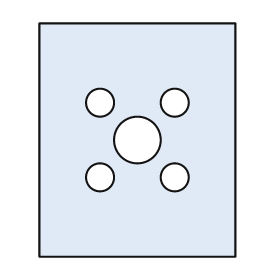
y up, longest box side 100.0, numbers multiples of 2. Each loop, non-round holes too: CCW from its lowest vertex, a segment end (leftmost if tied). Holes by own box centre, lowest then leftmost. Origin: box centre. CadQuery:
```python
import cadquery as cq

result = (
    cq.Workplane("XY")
    .moveTo(-42.0, -50.0)
    .lineTo(42.0, -50.0)
    .lineTo(42.0, 50.0)
    .lineTo(-42.0, 50.0)
    .close()
    .moveTo(-16.0, -16.0)
    .circle(6.0)
    .moveTo(16.0, -16.0)
    .circle(6.0)
    .moveTo(0.0, 0.0)
    .circle(10.0)
    .moveTo(-16.0, 16.0)
    .circle(6.0)
    .moveTo(16.0, 16.0)
    .circle(6.0)
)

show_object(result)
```